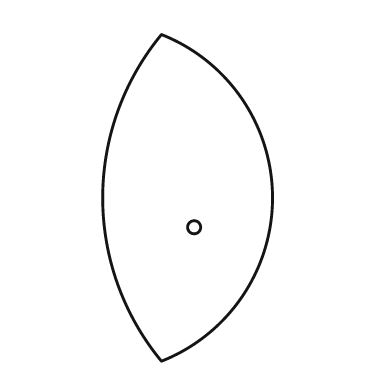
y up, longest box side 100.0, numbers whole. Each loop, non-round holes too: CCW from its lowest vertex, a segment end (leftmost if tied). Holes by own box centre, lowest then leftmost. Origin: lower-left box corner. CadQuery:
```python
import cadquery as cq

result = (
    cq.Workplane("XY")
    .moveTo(18.0, 0.0)
    .threePointArc((52.0, 50.0), (18.0, 100.0))
    .threePointArc((0.0, 50.0), (18.0, 0.0))
    .close()
    .moveTo(28.0, 41.0)
    .circle(2.0)
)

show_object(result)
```